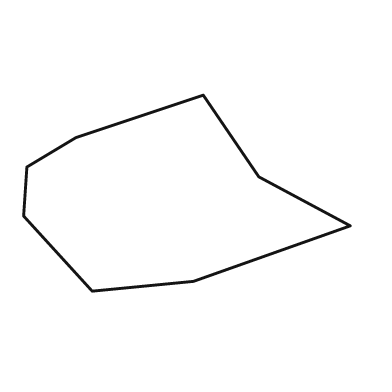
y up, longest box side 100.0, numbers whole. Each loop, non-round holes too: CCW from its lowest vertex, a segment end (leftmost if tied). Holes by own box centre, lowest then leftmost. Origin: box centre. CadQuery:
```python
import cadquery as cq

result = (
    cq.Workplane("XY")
    .moveTo(-29.0, -30.0)
    .lineTo(2.0, -27.0)
    .lineTo(50.0, -10.0)
    .lineTo(22.0, 5.0)
    .lineTo(5.0, 30.0)
    .lineTo(-34.0, 17.0)
    .lineTo(-49.0, 8.0)
    .lineTo(-50.0, -7.0)
    .close()
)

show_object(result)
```